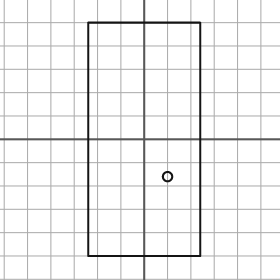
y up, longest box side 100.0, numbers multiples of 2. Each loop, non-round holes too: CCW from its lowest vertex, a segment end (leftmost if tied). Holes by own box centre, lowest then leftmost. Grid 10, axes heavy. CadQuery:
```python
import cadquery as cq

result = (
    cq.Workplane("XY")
    .moveTo(-24.0, -50.0)
    .lineTo(24.0, -50.0)
    .lineTo(24.0, 50.0)
    .lineTo(-24.0, 50.0)
    .close()
    .moveTo(10.0, -16.0)
    .circle(2.0)
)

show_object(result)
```